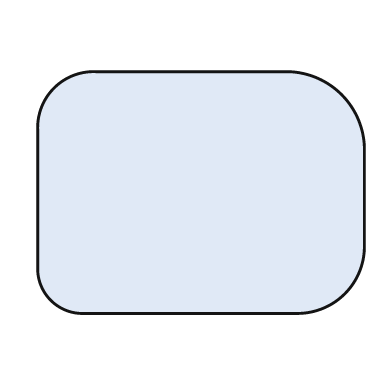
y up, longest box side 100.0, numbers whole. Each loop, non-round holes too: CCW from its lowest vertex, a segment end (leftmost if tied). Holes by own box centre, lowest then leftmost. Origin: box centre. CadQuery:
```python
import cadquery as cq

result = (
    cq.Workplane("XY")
    .moveTo(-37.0, -37.0)
    .lineTo(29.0, -37.0)
    .threePointArc((44.0, -31.0), (50.0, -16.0))
    .lineTo(50.0, 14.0)
    .threePointArc((43.0, 30.0), (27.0, 37.0))
    .lineTo(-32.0, 37.0)
    .threePointArc((-45.0, 32.0), (-50.0, 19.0))
    .lineTo(-50.0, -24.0)
    .threePointArc((-46.0, -33.0), (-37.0, -37.0))
    .close()
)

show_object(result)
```